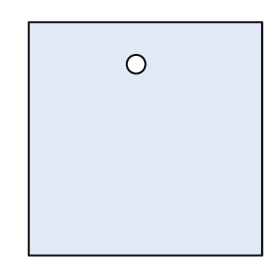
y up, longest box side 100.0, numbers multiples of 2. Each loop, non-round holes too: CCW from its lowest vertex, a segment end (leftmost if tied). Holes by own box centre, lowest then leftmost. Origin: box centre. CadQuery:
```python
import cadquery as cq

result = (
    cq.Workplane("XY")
    .moveTo(-50.0, -50.0)
    .lineTo(50.0, -50.0)
    .lineTo(50.0, 50.0)
    .lineTo(-50.0, 50.0)
    .close()
    .moveTo(-4.0, 32.0)
    .circle(4.0)
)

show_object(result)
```